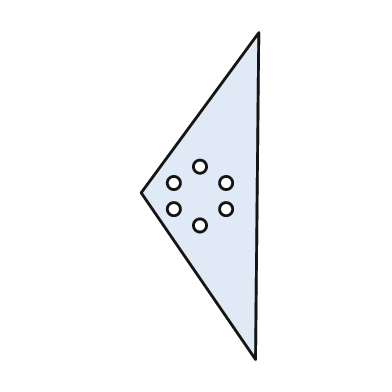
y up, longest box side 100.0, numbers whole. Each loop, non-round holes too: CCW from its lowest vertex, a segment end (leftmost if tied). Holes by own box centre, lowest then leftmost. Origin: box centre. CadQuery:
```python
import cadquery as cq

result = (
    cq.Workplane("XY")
    .moveTo(17.0, -50.0)
    .lineTo(18.0, 50.0)
    .lineTo(-18.0, 1.0)
    .close()
    .moveTo(0.0, -9.0)
    .circle(2.0)
    .moveTo(-8.0, -4.0)
    .circle(2.0)
    .moveTo(8.0, -4.0)
    .circle(2.0)
    .moveTo(-8.0, 4.0)
    .circle(2.0)
    .moveTo(8.0, 4.0)
    .circle(2.0)
    .moveTo(0.0, 9.0)
    .circle(2.0)
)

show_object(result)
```